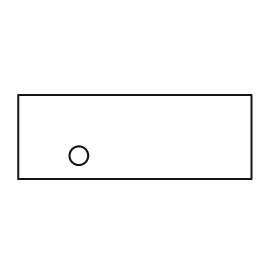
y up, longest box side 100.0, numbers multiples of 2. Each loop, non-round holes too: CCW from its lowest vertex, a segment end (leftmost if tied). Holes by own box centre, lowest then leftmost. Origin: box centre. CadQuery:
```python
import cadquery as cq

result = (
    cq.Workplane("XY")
    .moveTo(-50.0, -18.0)
    .lineTo(50.0, -18.0)
    .lineTo(50.0, 18.0)
    .lineTo(-50.0, 18.0)
    .close()
    .moveTo(-24.0, -8.0)
    .circle(4.0)
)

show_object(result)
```